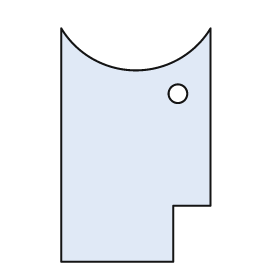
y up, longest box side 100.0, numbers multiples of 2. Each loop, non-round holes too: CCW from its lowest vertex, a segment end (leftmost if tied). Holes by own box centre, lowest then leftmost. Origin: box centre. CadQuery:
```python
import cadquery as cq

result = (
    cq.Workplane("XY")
    .moveTo(-32.0, -50.0)
    .lineTo(16.0, -50.0)
    .lineTo(16.0, -26.0)
    .lineTo(32.0, -26.0)
    .lineTo(32.0, 50.0)
    .threePointArc((0.0, 32.0), (-32.0, 50.0))
    .close()
    .moveTo(18.0, 22.0)
    .circle(4.0)
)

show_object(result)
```